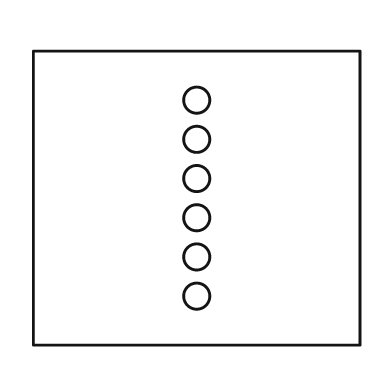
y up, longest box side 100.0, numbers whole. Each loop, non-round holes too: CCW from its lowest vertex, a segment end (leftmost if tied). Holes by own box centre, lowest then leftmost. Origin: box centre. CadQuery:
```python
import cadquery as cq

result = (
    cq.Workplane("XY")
    .moveTo(-50.0, -45.0)
    .lineTo(50.0, -45.0)
    .lineTo(50.0, 45.0)
    .lineTo(-50.0, 45.0)
    .close()
    .moveTo(0.0, -30.0)
    .circle(4.0)
    .moveTo(0.0, -18.0)
    .circle(4.0)
    .moveTo(0.0, -6.0)
    .circle(4.0)
    .moveTo(0.0, 6.0)
    .circle(4.0)
    .moveTo(0.0, 18.0)
    .circle(4.0)
    .moveTo(0.0, 30.0)
    .circle(4.0)
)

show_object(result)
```